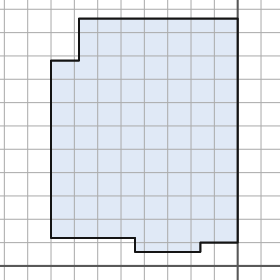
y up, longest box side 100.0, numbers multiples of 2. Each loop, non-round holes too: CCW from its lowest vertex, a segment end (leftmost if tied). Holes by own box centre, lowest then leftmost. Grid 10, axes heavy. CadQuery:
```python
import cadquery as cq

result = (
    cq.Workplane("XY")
    .moveTo(-44.0, 6.0)
    .lineTo(-16.0, 6.0)
    .lineTo(-16.0, 10.0)
    .lineTo(0.0, 10.0)
    .lineTo(0.0, 106.0)
    .lineTo(-68.0, 106.0)
    .lineTo(-68.0, 88.0)
    .lineTo(-80.0, 88.0)
    .lineTo(-80.0, 12.0)
    .lineTo(-44.0, 12.0)
    .close()
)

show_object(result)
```